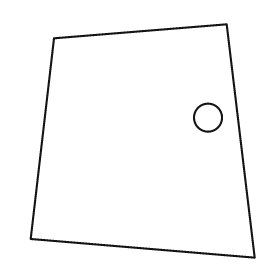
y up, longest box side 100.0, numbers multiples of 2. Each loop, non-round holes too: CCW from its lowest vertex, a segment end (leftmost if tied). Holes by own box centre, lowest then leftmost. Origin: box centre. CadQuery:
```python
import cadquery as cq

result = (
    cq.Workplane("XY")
    .moveTo(48.0, -50.0)
    .lineTo(36.0, 50.0)
    .lineTo(-38.0, 44.0)
    .lineTo(-48.0, -42.0)
    .close()
    .moveTo(28.0, 10.0)
    .circle(6.0)
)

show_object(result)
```